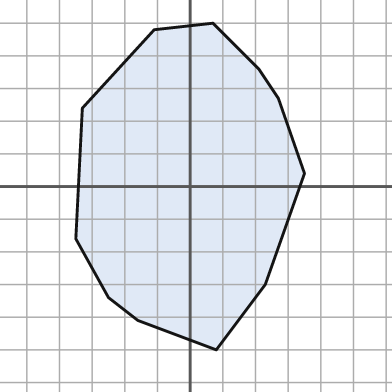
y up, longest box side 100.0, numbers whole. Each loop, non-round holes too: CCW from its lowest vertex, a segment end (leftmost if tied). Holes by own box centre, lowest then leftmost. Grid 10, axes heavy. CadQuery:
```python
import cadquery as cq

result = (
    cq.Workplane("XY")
    .moveTo(8.0, -50.0)
    .lineTo(23.0, -30.0)
    .lineTo(35.0, 4.0)
    .lineTo(27.0, 27.0)
    .lineTo(21.0, 36.0)
    .lineTo(7.0, 50.0)
    .lineTo(-11.0, 48.0)
    .lineTo(-33.0, 24.0)
    .lineTo(-35.0, -16.0)
    .lineTo(-25.0, -34.0)
    .lineTo(-16.0, -41.0)
    .close()
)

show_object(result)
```